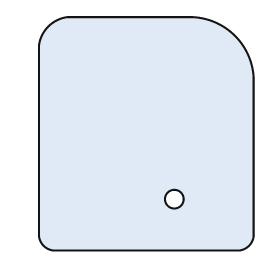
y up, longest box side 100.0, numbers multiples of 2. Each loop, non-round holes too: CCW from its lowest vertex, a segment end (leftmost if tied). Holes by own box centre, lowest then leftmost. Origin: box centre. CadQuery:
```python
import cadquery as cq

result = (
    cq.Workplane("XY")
    .moveTo(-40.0, -50.0)
    .lineTo(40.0, -50.0)
    .threePointArc((44.0, -48.0), (46.0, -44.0))
    .lineTo(46.0, 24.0)
    .threePointArc((38.0, 42.0), (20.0, 50.0))
    .lineTo(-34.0, 50.0)
    .threePointArc((-42.0, 46.0), (-46.0, 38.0))
    .lineTo(-46.0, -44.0)
    .threePointArc((-44.0, -48.0), (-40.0, -50.0))
    .close()
    .moveTo(12.0, -28.0)
    .circle(4.0)
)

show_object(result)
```